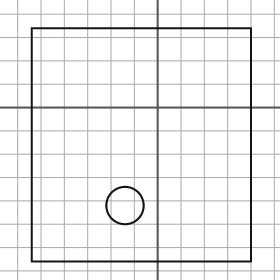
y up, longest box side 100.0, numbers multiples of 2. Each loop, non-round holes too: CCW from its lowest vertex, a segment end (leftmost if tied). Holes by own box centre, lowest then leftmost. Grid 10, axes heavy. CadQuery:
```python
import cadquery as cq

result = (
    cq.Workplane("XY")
    .moveTo(-54.0, -66.0)
    .lineTo(40.0, -66.0)
    .lineTo(40.0, 34.0)
    .lineTo(-54.0, 34.0)
    .close()
    .moveTo(-14.0, -42.0)
    .circle(8.0)
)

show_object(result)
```